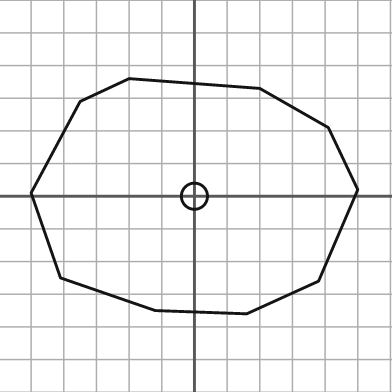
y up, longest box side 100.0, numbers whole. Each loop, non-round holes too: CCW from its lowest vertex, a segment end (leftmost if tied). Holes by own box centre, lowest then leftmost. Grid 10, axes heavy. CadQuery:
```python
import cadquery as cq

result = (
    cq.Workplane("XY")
    .moveTo(16.0, -36.0)
    .lineTo(38.0, -26.0)
    .lineTo(50.0, 2.0)
    .lineTo(41.0, 21.0)
    .lineTo(20.0, 33.0)
    .lineTo(-20.0, 36.0)
    .lineTo(-35.0, 29.0)
    .lineTo(-50.0, 1.0)
    .lineTo(-41.0, -25.0)
    .lineTo(-12.0, -35.0)
    .close()
    .moveTo(0.0, 0.0)
    .circle(4.0)
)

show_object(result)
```